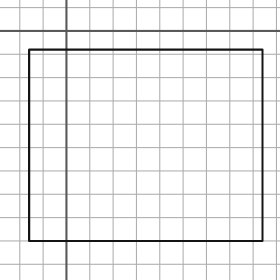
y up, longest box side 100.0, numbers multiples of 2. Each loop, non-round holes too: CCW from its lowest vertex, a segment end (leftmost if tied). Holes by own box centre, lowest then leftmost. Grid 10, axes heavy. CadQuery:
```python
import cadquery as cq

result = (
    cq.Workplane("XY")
    .moveTo(-16.0, -90.0)
    .lineTo(84.0, -90.0)
    .lineTo(84.0, -8.0)
    .lineTo(-16.0, -8.0)
    .close()
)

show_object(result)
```